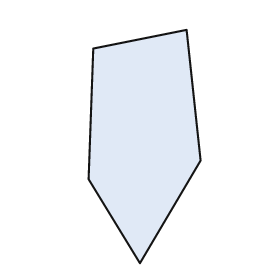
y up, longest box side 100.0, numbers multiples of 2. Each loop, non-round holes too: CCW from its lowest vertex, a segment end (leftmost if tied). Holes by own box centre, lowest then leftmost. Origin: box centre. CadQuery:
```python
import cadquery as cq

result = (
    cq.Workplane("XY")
    .moveTo(-2.0, -50.0)
    .lineTo(24.0, -6.0)
    .lineTo(18.0, 50.0)
    .lineTo(-22.0, 42.0)
    .lineTo(-24.0, -14.0)
    .close()
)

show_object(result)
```